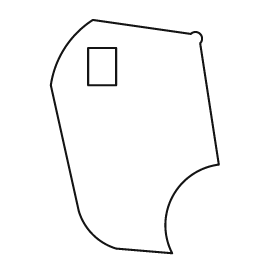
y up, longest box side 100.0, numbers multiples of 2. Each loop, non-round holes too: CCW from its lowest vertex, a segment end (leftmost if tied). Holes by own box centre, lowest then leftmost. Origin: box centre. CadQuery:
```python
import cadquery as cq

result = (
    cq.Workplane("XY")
    .moveTo(16.0, -50.0)
    .threePointArc((16.0, -26.0), (36.0, -12.0))
    .lineTo(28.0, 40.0)
    .threePointArc((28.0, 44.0), (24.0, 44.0))
    .lineTo(-18.0, 50.0)
    .threePointArc((-30.0, 38.0), (-36.0, 22.0))
    .lineTo(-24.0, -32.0)
    .threePointArc((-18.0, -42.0), (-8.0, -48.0))
    .close()
    .moveTo(-20.0, 22.0)
    .lineTo(-8.0, 22.0)
    .lineTo(-8.0, 38.0)
    .lineTo(-20.0, 38.0)
    .close()
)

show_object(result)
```